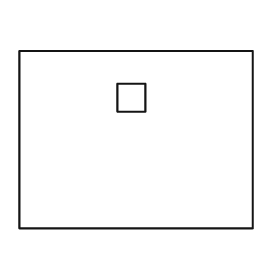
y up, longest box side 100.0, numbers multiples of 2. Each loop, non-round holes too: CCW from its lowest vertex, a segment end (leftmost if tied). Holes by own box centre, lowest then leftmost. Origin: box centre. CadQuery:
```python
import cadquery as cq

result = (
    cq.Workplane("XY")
    .moveTo(-50.0, -38.0)
    .lineTo(50.0, -38.0)
    .lineTo(50.0, 38.0)
    .lineTo(-50.0, 38.0)
    .close()
    .moveTo(-8.0, 12.0)
    .lineTo(4.0, 12.0)
    .lineTo(4.0, 24.0)
    .lineTo(-8.0, 24.0)
    .close()
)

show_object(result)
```